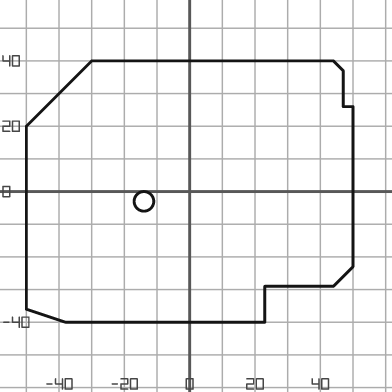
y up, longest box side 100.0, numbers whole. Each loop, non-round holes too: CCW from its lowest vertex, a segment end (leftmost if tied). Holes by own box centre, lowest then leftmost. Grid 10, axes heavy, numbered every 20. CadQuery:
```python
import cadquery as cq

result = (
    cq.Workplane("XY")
    .moveTo(-38.0, -40.0)
    .lineTo(23.0, -40.0)
    .lineTo(23.0, -29.0)
    .lineTo(44.0, -29.0)
    .lineTo(50.0, -23.0)
    .lineTo(50.0, 26.0)
    .lineTo(47.0, 26.0)
    .lineTo(47.0, 37.0)
    .lineTo(44.0, 40.0)
    .lineTo(-30.0, 40.0)
    .lineTo(-50.0, 20.0)
    .lineTo(-50.0, -36.0)
    .close()
    .moveTo(-14.0, -3.0)
    .circle(3.0)
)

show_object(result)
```